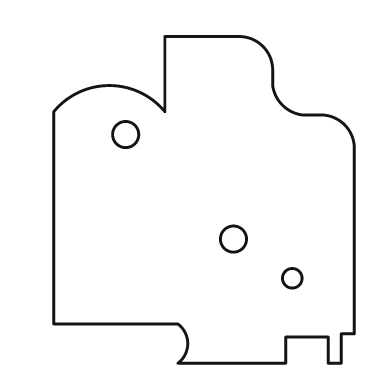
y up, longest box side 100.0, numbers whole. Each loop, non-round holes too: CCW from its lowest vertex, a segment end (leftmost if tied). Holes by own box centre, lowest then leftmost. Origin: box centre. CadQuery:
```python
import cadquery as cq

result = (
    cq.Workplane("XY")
    .moveTo(-8.0, -50.0)
    .lineTo(25.0, -50.0)
    .lineTo(25.0, -42.0)
    .lineTo(38.0, -42.0)
    .lineTo(38.0, -50.0)
    .lineTo(42.0, -50.0)
    .lineTo(42.0, -41.0)
    .lineTo(46.0, -41.0)
    .lineTo(46.0, 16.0)
    .threePointArc((43.0, 23.0), (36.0, 26.0))
    .lineTo(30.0, 26.0)
    .threePointArc((24.0, 29.0), (21.0, 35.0))
    .lineTo(21.0, 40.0)
    .threePointArc((18.0, 47.0), (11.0, 50.0))
    .lineTo(-12.0, 50.0)
    .lineTo(-12.0, 27.0)
    .threePointArc((-29.0, 35.0), (-46.0, 27.0))
    .lineTo(-46.0, -38.0)
    .lineTo(-8.0, -38.0)
    .threePointArc((-5.0, -44.0), (-8.0, -50.0))
    .close()
    .moveTo(27.0, -24.0)
    .circle(3.0)
    .moveTo(9.0, -12.0)
    .circle(4.0)
    .moveTo(-24.0, 20.0)
    .circle(4.0)
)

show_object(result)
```